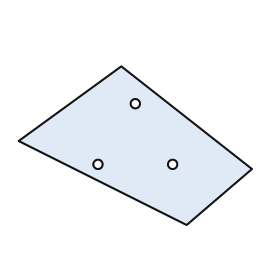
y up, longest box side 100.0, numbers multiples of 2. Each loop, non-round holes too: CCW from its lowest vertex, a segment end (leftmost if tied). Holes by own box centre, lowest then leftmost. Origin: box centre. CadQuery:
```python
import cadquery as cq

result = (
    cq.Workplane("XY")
    .moveTo(22.0, -34.0)
    .lineTo(50.0, -10.0)
    .lineTo(-6.0, 34.0)
    .lineTo(-50.0, 2.0)
    .close()
    .moveTo(-16.0, -8.0)
    .circle(2.0)
    .moveTo(16.0, -8.0)
    .circle(2.0)
    .moveTo(0.0, 18.0)
    .circle(2.0)
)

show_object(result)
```